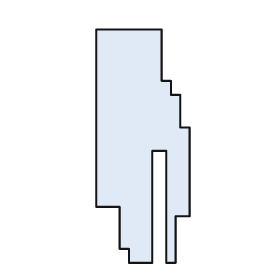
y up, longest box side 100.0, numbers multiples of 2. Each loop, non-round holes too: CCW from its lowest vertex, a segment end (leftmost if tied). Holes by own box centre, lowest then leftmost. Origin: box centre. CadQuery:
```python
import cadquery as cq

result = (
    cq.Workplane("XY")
    .moveTo(-6.0, -50.0)
    .lineTo(4.0, -50.0)
    .lineTo(4.0, -2.0)
    .lineTo(10.0, -2.0)
    .lineTo(10.0, -50.0)
    .lineTo(14.0, -50.0)
    .lineTo(14.0, -30.0)
    .lineTo(20.0, -30.0)
    .lineTo(20.0, 8.0)
    .lineTo(16.0, 8.0)
    .lineTo(16.0, 22.0)
    .lineTo(12.0, 22.0)
    .lineTo(12.0, 28.0)
    .lineTo(8.0, 28.0)
    .lineTo(8.0, 50.0)
    .lineTo(-20.0, 50.0)
    .lineTo(-20.0, -26.0)
    .lineTo(-10.0, -26.0)
    .lineTo(-10.0, -44.0)
    .lineTo(-6.0, -44.0)
    .close()
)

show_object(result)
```